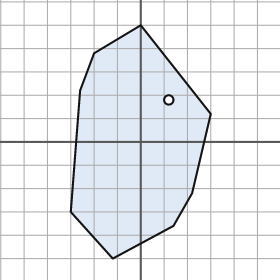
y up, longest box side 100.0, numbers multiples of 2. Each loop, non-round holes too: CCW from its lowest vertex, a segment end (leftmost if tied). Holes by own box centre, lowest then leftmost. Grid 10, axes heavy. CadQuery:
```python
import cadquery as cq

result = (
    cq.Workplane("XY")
    .moveTo(-12.0, -50.0)
    .lineTo(14.0, -36.0)
    .lineTo(22.0, -22.0)
    .lineTo(30.0, 12.0)
    .lineTo(0.0, 50.0)
    .lineTo(-20.0, 38.0)
    .lineTo(-26.0, 22.0)
    .lineTo(-30.0, -30.0)
    .close()
    .moveTo(12.0, 18.0)
    .circle(2.0)
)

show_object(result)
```